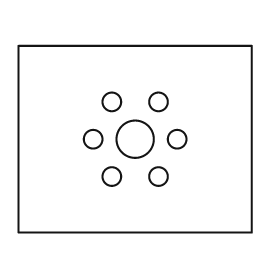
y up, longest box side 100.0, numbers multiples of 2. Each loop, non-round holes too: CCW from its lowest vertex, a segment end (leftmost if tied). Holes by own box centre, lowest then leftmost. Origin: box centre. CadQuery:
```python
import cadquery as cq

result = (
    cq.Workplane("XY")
    .moveTo(-50.0, -40.0)
    .lineTo(50.0, -40.0)
    .lineTo(50.0, 40.0)
    .lineTo(-50.0, 40.0)
    .close()
    .moveTo(-10.0, -16.0)
    .circle(4.0)
    .moveTo(10.0, -16.0)
    .circle(4.0)
    .moveTo(-18.0, 0.0)
    .circle(4.0)
    .moveTo(0.0, 0.0)
    .circle(8.0)
    .moveTo(18.0, 0.0)
    .circle(4.0)
    .moveTo(-10.0, 16.0)
    .circle(4.0)
    .moveTo(10.0, 16.0)
    .circle(4.0)
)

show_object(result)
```